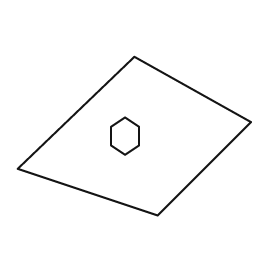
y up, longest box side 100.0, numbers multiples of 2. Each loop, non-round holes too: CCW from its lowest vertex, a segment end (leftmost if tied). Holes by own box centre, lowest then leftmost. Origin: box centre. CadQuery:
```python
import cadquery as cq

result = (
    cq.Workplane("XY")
    .moveTo(10.0, -34.0)
    .lineTo(50.0, 6.0)
    .lineTo(0.0, 34.0)
    .lineTo(-50.0, -14.0)
    .close()
    .moveTo(-4.0, -8.0)
    .lineTo(2.0, -4.0)
    .lineTo(2.0, 4.0)
    .lineTo(-4.0, 8.0)
    .lineTo(-10.0, 4.0)
    .lineTo(-10.0, -4.0)
    .close()
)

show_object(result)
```